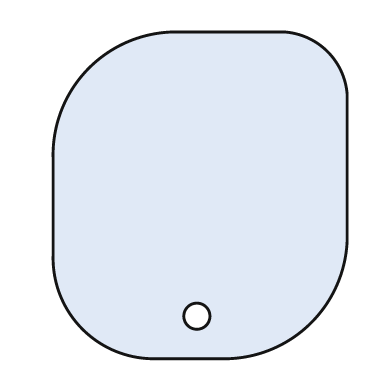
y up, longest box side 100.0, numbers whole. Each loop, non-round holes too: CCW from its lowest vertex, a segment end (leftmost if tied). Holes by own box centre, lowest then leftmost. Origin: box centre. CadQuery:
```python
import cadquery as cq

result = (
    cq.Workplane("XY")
    .moveTo(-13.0, -50.0)
    .lineTo(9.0, -50.0)
    .threePointArc((34.0, -39.0), (45.0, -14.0))
    .lineTo(45.0, 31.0)
    .threePointArc((39.0, 44.0), (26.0, 50.0))
    .lineTo(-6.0, 50.0)
    .threePointArc((-34.0, 39.0), (-45.0, 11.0))
    .lineTo(-45.0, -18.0)
    .threePointArc((-36.0, -41.0), (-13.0, -50.0))
    .close()
    .moveTo(-1.0, -37.0)
    .circle(4.0)
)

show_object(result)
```